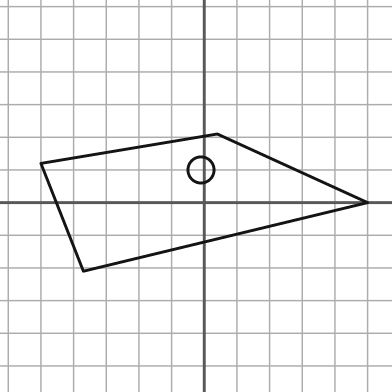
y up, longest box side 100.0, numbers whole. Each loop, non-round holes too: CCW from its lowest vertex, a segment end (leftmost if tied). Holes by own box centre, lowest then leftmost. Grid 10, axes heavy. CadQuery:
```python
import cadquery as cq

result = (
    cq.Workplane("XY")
    .moveTo(-37.0, -21.0)
    .lineTo(50.0, 0.0)
    .lineTo(4.0, 21.0)
    .lineTo(-50.0, 12.0)
    .close()
    .moveTo(-1.0, 10.0)
    .circle(4.0)
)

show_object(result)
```